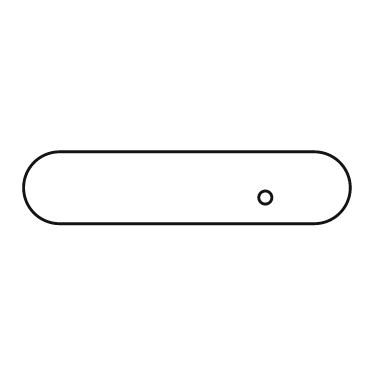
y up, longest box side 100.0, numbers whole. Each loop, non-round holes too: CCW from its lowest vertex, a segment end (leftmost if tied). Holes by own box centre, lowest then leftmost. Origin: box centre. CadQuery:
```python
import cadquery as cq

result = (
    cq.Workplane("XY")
    .moveTo(-39.0, -11.0)
    .lineTo(39.0, -11.0)
    .threePointArc((50.0, 0.0), (39.0, 11.0))
    .lineTo(-39.0, 11.0)
    .threePointArc((-50.0, 0.0), (-39.0, -11.0))
    .close()
    .moveTo(24.0, -3.0)
    .circle(2.0)
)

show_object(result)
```